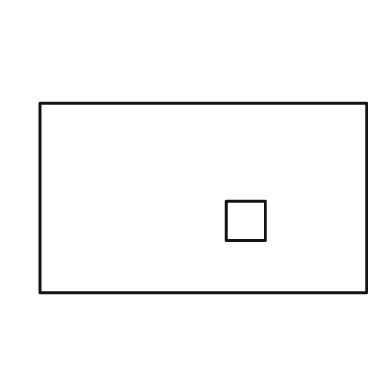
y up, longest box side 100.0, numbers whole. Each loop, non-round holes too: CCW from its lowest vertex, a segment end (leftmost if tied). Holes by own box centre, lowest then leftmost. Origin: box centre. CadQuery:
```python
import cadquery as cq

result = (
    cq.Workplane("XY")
    .moveTo(-50.0, -29.0)
    .lineTo(50.0, -29.0)
    .lineTo(50.0, 29.0)
    .lineTo(-50.0, 29.0)
    .close()
    .moveTo(7.0, -13.0)
    .lineTo(19.0, -13.0)
    .lineTo(19.0, -1.0)
    .lineTo(7.0, -1.0)
    .close()
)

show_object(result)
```